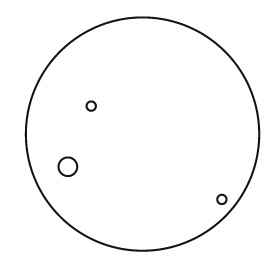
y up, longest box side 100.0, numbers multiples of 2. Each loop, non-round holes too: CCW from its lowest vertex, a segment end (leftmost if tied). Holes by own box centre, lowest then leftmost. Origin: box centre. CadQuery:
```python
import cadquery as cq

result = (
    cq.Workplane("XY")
    .moveTo(0.0, 0.0)
    .circle(50.0)
    .moveTo(34.0, -28.0)
    .circle(2.0)
    .moveTo(-32.0, -14.0)
    .circle(4.0)
    .moveTo(-22.0, 12.0)
    .circle(2.0)
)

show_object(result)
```